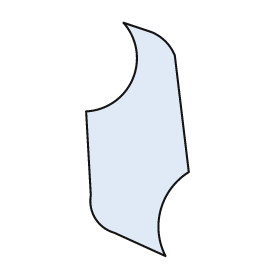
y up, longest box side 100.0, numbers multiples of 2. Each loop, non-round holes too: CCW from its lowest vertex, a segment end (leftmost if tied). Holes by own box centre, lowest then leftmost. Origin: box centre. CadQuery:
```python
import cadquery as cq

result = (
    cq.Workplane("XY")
    .moveTo(12.0, -50.0)
    .threePointArc((10.0, -30.0), (22.0, -14.0))
    .lineTo(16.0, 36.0)
    .threePointArc((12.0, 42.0), (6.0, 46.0))
    .lineTo(-6.0, 50.0)
    .threePointArc((-2.0, 26.0), (-22.0, 12.0))
    .lineTo(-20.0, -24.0)
    .threePointArc((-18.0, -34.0), (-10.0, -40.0))
    .close()
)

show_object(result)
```